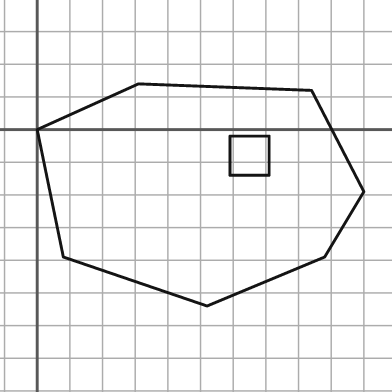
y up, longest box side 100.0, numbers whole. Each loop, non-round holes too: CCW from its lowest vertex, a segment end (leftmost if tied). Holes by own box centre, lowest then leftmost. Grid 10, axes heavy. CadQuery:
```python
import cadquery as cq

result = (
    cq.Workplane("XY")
    .moveTo(52.0, -54.0)
    .lineTo(88.0, -39.0)
    .lineTo(100.0, -19.0)
    .lineTo(84.0, 12.0)
    .lineTo(31.0, 14.0)
    .lineTo(0.0, 0.0)
    .lineTo(8.0, -39.0)
    .close()
    .moveTo(59.0, -14.0)
    .lineTo(71.0, -14.0)
    .lineTo(71.0, -2.0)
    .lineTo(59.0, -2.0)
    .close()
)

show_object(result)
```